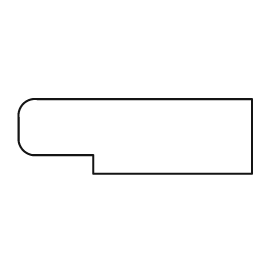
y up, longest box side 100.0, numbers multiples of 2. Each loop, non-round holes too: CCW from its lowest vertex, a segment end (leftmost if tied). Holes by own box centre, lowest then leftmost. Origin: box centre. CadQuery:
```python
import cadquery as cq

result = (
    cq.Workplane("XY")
    .moveTo(-18.0, -16.0)
    .lineTo(50.0, -16.0)
    .lineTo(50.0, 16.0)
    .lineTo(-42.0, 16.0)
    .threePointArc((-48.0, 14.0), (-50.0, 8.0))
    .lineTo(-50.0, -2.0)
    .threePointArc((-48.0, -6.0), (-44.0, -8.0))
    .lineTo(-18.0, -8.0)
    .close()
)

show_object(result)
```